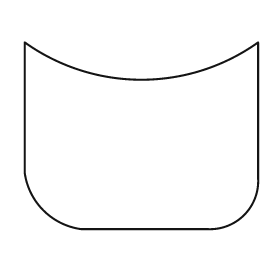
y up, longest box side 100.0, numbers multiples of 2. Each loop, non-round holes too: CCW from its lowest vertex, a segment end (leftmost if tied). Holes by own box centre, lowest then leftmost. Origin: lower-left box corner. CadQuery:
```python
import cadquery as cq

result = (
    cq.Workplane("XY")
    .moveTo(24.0, 0.0)
    .lineTo(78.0, 0.0)
    .threePointArc((94.0, 6.0), (100.0, 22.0))
    .lineTo(100.0, 80.0)
    .threePointArc((50.0, 64.0), (0.0, 80.0))
    .lineTo(0.0, 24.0)
    .threePointArc((8.0, 8.0), (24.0, 0.0))
    .close()
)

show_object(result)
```